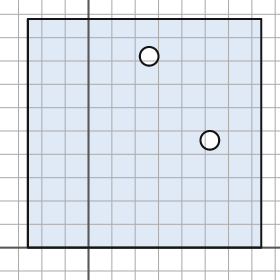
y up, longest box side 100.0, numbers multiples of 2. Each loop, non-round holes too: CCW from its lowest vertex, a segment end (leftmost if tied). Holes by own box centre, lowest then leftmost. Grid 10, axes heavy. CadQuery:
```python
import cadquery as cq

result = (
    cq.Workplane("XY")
    .moveTo(-26.0, 0.0)
    .lineTo(74.0, 0.0)
    .lineTo(74.0, 98.0)
    .lineTo(-26.0, 98.0)
    .close()
    .moveTo(52.0, 46.0)
    .circle(4.0)
    .moveTo(26.0, 82.0)
    .circle(4.0)
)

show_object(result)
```